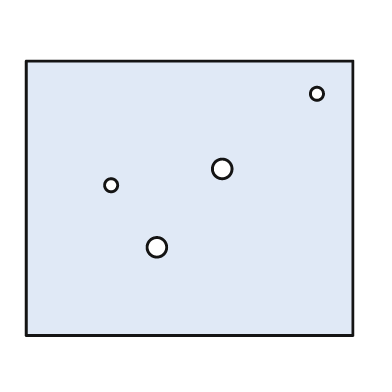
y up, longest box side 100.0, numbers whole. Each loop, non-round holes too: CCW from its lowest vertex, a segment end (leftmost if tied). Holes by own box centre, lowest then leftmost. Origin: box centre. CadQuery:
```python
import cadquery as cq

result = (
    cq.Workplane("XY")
    .moveTo(-50.0, -42.0)
    .lineTo(50.0, -42.0)
    .lineTo(50.0, 42.0)
    .lineTo(-50.0, 42.0)
    .close()
    .moveTo(-10.0, -15.0)
    .circle(3.0)
    .moveTo(-24.0, 4.0)
    .circle(2.0)
    .moveTo(10.0, 9.0)
    .circle(3.0)
    .moveTo(39.0, 32.0)
    .circle(2.0)
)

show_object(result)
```